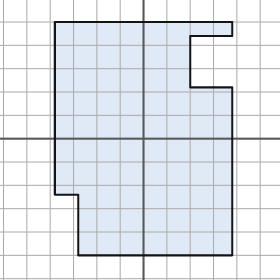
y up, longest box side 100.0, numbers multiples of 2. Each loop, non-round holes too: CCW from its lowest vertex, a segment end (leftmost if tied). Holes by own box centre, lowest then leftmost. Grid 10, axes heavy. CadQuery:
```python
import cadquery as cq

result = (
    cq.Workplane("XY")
    .moveTo(-28.0, -50.0)
    .lineTo(38.0, -50.0)
    .lineTo(38.0, 22.0)
    .lineTo(20.0, 22.0)
    .lineTo(20.0, 44.0)
    .lineTo(38.0, 44.0)
    .lineTo(38.0, 50.0)
    .lineTo(-38.0, 50.0)
    .lineTo(-38.0, -24.0)
    .lineTo(-28.0, -24.0)
    .close()
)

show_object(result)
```